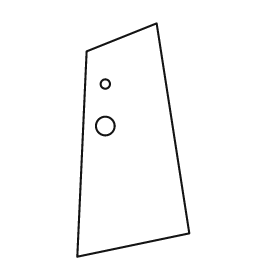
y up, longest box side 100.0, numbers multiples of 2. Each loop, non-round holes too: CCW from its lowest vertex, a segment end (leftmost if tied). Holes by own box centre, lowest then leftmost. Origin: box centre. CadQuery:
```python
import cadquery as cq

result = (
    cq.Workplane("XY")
    .moveTo(-24.0, -50.0)
    .lineTo(24.0, -40.0)
    .lineTo(10.0, 50.0)
    .lineTo(-20.0, 38.0)
    .close()
    .moveTo(-12.0, 6.0)
    .circle(4.0)
    .moveTo(-12.0, 24.0)
    .circle(2.0)
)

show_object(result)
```